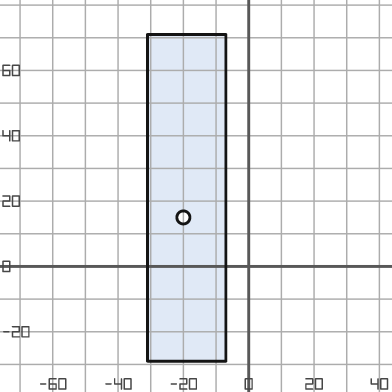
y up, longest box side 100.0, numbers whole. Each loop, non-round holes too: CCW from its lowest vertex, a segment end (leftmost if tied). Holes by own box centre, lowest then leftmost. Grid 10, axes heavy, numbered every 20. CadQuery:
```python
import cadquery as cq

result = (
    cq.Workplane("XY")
    .moveTo(-31.0, -29.0)
    .lineTo(-7.0, -29.0)
    .lineTo(-7.0, 71.0)
    .lineTo(-31.0, 71.0)
    .close()
    .moveTo(-20.0, 15.0)
    .circle(2.0)
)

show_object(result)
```